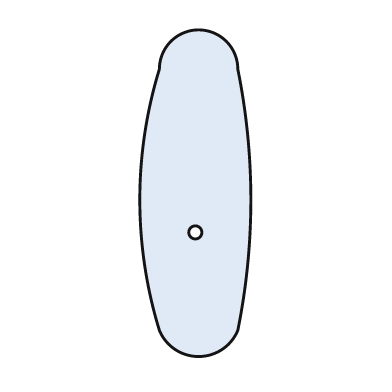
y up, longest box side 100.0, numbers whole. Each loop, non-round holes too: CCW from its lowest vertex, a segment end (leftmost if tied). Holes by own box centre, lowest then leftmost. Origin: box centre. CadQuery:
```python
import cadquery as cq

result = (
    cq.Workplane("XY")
    .moveTo(-11.0, -42.0)
    .threePointArc((1.0, -50.0), (13.0, -42.0))
    .threePointArc((17.0, -2.0), (13.0, 38.0))
    .threePointArc((1.0, 50.0), (-11.0, 38.0))
    .threePointArc((-17.0, -2.0), (-11.0, -42.0))
    .close()
    .moveTo(0.0, -12.0)
    .circle(2.0)
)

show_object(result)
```